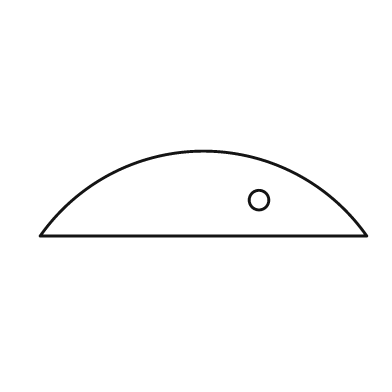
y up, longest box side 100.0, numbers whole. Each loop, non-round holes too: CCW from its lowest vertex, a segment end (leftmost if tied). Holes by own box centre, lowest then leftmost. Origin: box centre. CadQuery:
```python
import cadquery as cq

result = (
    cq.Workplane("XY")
    .moveTo(-50.0, -13.0)
    .lineTo(50.0, -13.0)
    .threePointArc((0.0, 13.0), (-50.0, -13.0))
    .close()
    .moveTo(17.0, -2.0)
    .circle(3.0)
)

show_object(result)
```